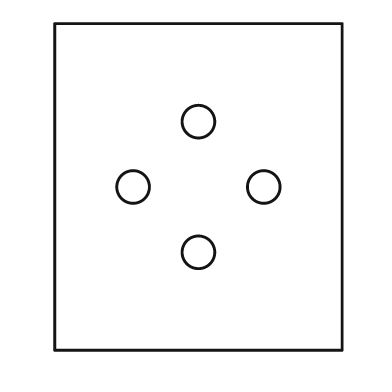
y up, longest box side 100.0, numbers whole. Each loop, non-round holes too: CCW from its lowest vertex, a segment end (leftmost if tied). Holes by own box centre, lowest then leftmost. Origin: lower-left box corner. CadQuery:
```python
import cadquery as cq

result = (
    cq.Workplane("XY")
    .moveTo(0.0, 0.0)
    .lineTo(88.0, 0.0)
    .lineTo(88.0, 100.0)
    .lineTo(0.0, 100.0)
    .close()
    .moveTo(44.0, 30.0)
    .circle(5.0)
    .moveTo(24.0, 50.0)
    .circle(5.0)
    .moveTo(64.0, 50.0)
    .circle(5.0)
    .moveTo(44.0, 70.0)
    .circle(5.0)
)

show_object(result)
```